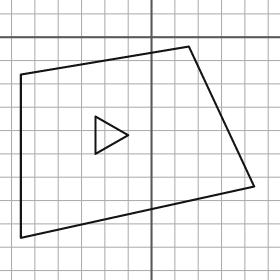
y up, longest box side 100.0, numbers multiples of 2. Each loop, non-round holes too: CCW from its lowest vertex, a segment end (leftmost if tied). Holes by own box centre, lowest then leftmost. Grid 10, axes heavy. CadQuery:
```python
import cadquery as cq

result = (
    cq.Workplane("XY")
    .moveTo(-56.0, -86.0)
    .lineTo(44.0, -64.0)
    .lineTo(16.0, -4.0)
    .lineTo(-56.0, -16.0)
    .close()
    .moveTo(-24.0, -50.0)
    .lineTo(-10.0, -42.0)
    .lineTo(-24.0, -34.0)
    .close()
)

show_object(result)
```